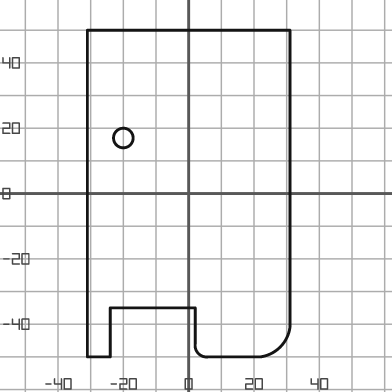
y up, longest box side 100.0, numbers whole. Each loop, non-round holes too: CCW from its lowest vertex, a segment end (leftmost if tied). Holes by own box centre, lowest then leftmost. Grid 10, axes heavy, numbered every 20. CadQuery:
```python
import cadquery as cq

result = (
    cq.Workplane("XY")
    .moveTo(-31.0, -50.0)
    .lineTo(-24.0, -50.0)
    .lineTo(-24.0, -35.0)
    .lineTo(2.0, -35.0)
    .lineTo(2.0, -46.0)
    .threePointArc((3.0, -49.0), (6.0, -50.0))
    .lineTo(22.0, -50.0)
    .threePointArc((28.0, -47.0), (31.0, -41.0))
    .lineTo(31.0, 50.0)
    .lineTo(-31.0, 50.0)
    .close()
    .moveTo(-20.0, 17.0)
    .circle(3.0)
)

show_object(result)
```